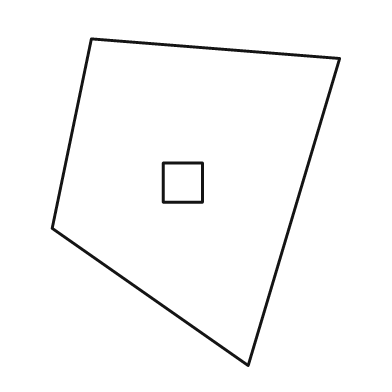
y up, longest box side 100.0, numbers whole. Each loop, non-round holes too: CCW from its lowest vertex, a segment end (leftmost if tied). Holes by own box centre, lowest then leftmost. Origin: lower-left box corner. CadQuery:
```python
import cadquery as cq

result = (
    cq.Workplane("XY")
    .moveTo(60.0, 0.0)
    .lineTo(88.0, 94.0)
    .lineTo(12.0, 100.0)
    .lineTo(0.0, 42.0)
    .close()
    .moveTo(34.0, 50.0)
    .lineTo(46.0, 50.0)
    .lineTo(46.0, 62.0)
    .lineTo(34.0, 62.0)
    .close()
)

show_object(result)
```